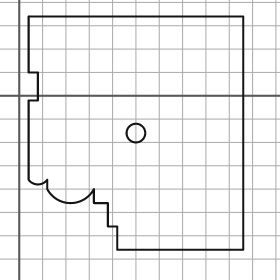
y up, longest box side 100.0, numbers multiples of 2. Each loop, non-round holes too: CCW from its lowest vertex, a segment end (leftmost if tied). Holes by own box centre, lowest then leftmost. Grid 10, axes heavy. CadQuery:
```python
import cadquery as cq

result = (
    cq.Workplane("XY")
    .moveTo(42.0, -66.0)
    .lineTo(96.0, -66.0)
    .lineTo(96.0, 34.0)
    .lineTo(4.0, 34.0)
    .lineTo(4.0, 10.0)
    .lineTo(8.0, 10.0)
    .lineTo(8.0, -2.0)
    .lineTo(4.0, -2.0)
    .lineTo(4.0, -36.0)
    .threePointArc((8.0, -38.0), (12.0, -36.0))
    .lineTo(12.0, -40.0)
    .threePointArc((22.0, -46.0), (32.0, -40.0))
    .lineTo(32.0, -46.0)
    .lineTo(38.0, -46.0)
    .lineTo(38.0, -56.0)
    .lineTo(42.0, -56.0)
    .close()
    .moveTo(50.0, -16.0)
    .circle(4.0)
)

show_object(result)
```